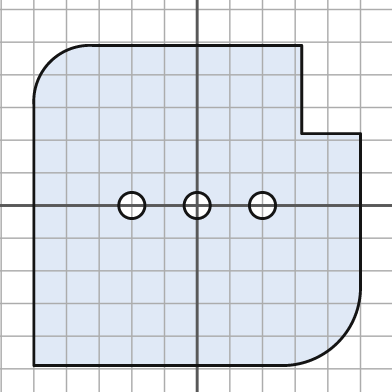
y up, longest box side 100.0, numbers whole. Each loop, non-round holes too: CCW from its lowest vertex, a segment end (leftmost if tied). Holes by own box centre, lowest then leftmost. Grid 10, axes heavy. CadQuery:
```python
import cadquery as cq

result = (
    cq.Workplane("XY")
    .moveTo(-50.0, -49.0)
    .lineTo(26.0, -49.0)
    .threePointArc((43.0, -42.0), (50.0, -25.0))
    .lineTo(50.0, 22.0)
    .lineTo(32.0, 22.0)
    .lineTo(32.0, 49.0)
    .lineTo(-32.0, 49.0)
    .threePointArc((-45.0, 44.0), (-50.0, 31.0))
    .close()
    .moveTo(-20.0, 0.0)
    .circle(4.0)
    .moveTo(0.0, 0.0)
    .circle(4.0)
    .moveTo(20.0, 0.0)
    .circle(4.0)
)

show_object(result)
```